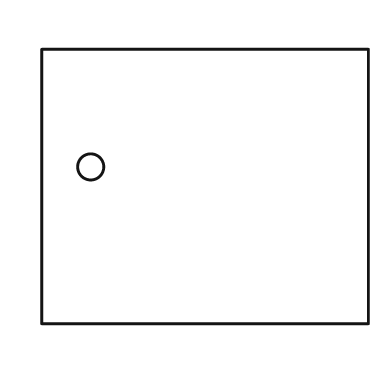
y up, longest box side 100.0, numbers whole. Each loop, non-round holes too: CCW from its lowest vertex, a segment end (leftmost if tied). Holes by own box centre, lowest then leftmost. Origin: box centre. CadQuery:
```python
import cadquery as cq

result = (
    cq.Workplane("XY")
    .moveTo(-50.0, -42.0)
    .lineTo(50.0, -42.0)
    .lineTo(50.0, 42.0)
    .lineTo(-50.0, 42.0)
    .close()
    .moveTo(-35.0, 6.0)
    .circle(4.0)
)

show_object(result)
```